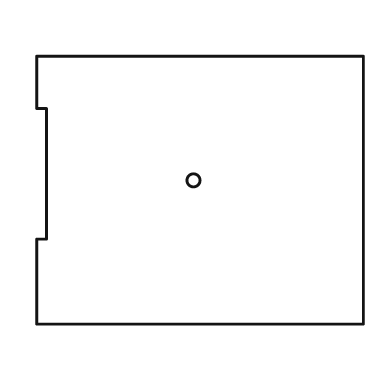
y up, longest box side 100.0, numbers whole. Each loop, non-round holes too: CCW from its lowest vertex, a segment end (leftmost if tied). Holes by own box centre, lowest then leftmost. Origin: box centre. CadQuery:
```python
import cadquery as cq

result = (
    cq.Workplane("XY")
    .moveTo(-50.0, -41.0)
    .lineTo(50.0, -41.0)
    .lineTo(50.0, 41.0)
    .lineTo(-50.0, 41.0)
    .lineTo(-50.0, 25.0)
    .lineTo(-47.0, 25.0)
    .lineTo(-47.0, -15.0)
    .lineTo(-50.0, -15.0)
    .close()
    .moveTo(-2.0, 3.0)
    .circle(2.0)
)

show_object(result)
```